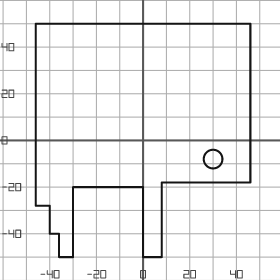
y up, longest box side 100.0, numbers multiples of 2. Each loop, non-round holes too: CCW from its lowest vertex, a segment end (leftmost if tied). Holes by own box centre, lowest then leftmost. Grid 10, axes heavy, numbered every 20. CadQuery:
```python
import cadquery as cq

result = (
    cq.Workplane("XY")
    .moveTo(-36.0, -50.0)
    .lineTo(-30.0, -50.0)
    .lineTo(-30.0, -20.0)
    .lineTo(0.0, -20.0)
    .lineTo(0.0, -50.0)
    .lineTo(8.0, -50.0)
    .lineTo(8.0, -18.0)
    .lineTo(46.0, -18.0)
    .lineTo(46.0, 50.0)
    .lineTo(-46.0, 50.0)
    .lineTo(-46.0, -28.0)
    .lineTo(-40.0, -28.0)
    .lineTo(-40.0, -40.0)
    .lineTo(-36.0, -40.0)
    .close()
    .moveTo(30.0, -8.0)
    .circle(4.0)
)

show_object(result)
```